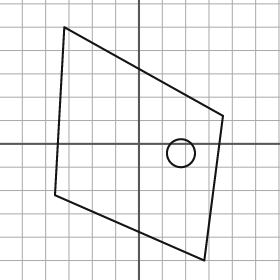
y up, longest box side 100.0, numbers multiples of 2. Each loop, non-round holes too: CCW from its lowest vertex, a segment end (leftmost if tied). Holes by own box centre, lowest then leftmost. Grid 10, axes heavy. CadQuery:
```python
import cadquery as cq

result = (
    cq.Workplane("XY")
    .moveTo(28.0, -50.0)
    .lineTo(36.0, 12.0)
    .lineTo(-32.0, 50.0)
    .lineTo(-36.0, -22.0)
    .close()
    .moveTo(18.0, -4.0)
    .circle(6.0)
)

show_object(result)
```